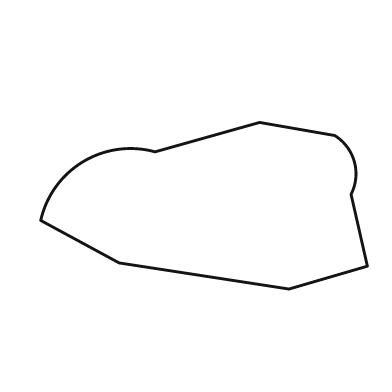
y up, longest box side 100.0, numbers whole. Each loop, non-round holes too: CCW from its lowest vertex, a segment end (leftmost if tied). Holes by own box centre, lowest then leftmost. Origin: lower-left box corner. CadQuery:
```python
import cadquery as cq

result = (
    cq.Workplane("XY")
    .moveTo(76.0, 0.0)
    .lineTo(100.0, 7.0)
    .lineTo(95.0, 29.0)
    .threePointArc((96.0, 39.0), (90.0, 47.0))
    .lineTo(67.0, 51.0)
    .lineTo(35.0, 42.0)
    .threePointArc((13.0, 39.0), (0.0, 21.0))
    .lineTo(24.0, 8.0)
    .close()
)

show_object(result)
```